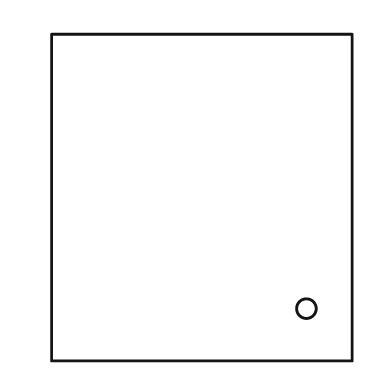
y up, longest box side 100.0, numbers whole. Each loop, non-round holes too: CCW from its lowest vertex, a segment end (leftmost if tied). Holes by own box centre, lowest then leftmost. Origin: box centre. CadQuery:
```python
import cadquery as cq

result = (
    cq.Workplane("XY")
    .moveTo(-46.0, -50.0)
    .lineTo(46.0, -50.0)
    .lineTo(46.0, 50.0)
    .lineTo(-46.0, 50.0)
    .close()
    .moveTo(32.0, -34.0)
    .circle(3.0)
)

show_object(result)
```